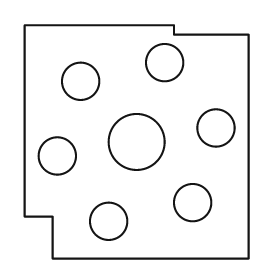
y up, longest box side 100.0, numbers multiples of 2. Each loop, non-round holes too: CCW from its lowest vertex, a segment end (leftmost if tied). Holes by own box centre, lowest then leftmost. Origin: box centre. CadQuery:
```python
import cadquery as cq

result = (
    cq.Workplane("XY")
    .moveTo(-36.0, -50.0)
    .lineTo(48.0, -50.0)
    .lineTo(48.0, 46.0)
    .lineTo(16.0, 46.0)
    .lineTo(16.0, 50.0)
    .lineTo(-48.0, 50.0)
    .lineTo(-48.0, -32.0)
    .lineTo(-36.0, -32.0)
    .close()
    .moveTo(-12.0, -34.0)
    .circle(8.0)
    .moveTo(24.0, -26.0)
    .circle(8.0)
    .moveTo(-34.0, -6.0)
    .circle(8.0)
    .moveTo(0.0, 0.0)
    .circle(12.0)
    .moveTo(34.0, 6.0)
    .circle(8.0)
    .moveTo(-24.0, 26.0)
    .circle(8.0)
    .moveTo(12.0, 34.0)
    .circle(8.0)
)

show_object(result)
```